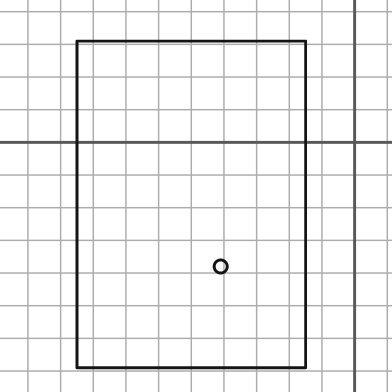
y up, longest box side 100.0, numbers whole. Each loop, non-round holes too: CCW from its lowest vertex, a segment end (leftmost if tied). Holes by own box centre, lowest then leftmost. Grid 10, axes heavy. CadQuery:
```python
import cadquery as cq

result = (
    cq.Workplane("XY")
    .moveTo(-85.0, -69.0)
    .lineTo(-15.0, -69.0)
    .lineTo(-15.0, 31.0)
    .lineTo(-85.0, 31.0)
    .close()
    .moveTo(-41.0, -38.0)
    .circle(2.0)
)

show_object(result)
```